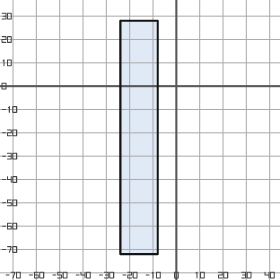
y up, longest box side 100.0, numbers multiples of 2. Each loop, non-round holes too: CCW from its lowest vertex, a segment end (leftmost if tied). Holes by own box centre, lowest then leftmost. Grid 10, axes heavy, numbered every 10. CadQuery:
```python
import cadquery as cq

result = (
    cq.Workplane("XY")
    .moveTo(-24.0, -72.0)
    .lineTo(-8.0, -72.0)
    .lineTo(-8.0, 28.0)
    .lineTo(-24.0, 28.0)
    .close()
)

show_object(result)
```